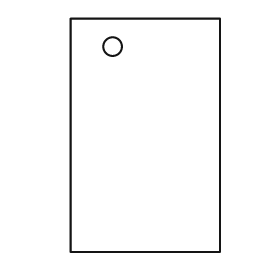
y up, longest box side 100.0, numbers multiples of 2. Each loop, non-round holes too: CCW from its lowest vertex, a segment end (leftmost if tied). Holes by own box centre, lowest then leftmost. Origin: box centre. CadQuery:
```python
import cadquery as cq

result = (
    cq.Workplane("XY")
    .moveTo(-32.0, -50.0)
    .lineTo(32.0, -50.0)
    .lineTo(32.0, 50.0)
    .lineTo(-32.0, 50.0)
    .close()
    .moveTo(-14.0, 38.0)
    .circle(4.0)
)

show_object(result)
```